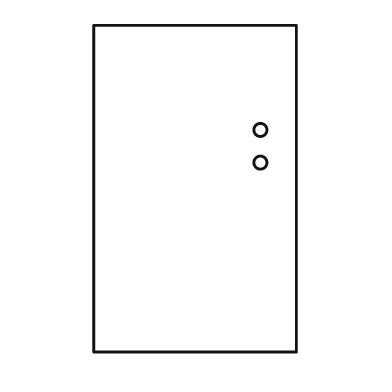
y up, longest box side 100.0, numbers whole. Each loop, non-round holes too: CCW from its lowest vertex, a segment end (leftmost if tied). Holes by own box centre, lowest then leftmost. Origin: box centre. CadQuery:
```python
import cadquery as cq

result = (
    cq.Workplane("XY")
    .moveTo(-31.0, -50.0)
    .lineTo(31.0, -50.0)
    .lineTo(31.0, 50.0)
    .lineTo(-31.0, 50.0)
    .close()
    .moveTo(20.0, 8.0)
    .circle(2.0)
    .moveTo(20.0, 18.0)
    .circle(2.0)
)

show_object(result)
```